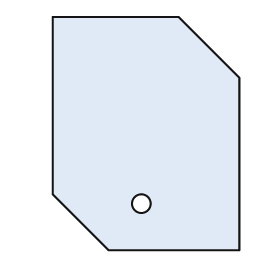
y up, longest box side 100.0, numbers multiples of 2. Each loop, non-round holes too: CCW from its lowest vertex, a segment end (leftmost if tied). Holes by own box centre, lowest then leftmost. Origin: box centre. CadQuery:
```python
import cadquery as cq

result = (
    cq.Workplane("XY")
    .moveTo(-16.0, -50.0)
    .lineTo(40.0, -50.0)
    .lineTo(40.0, 24.0)
    .lineTo(14.0, 50.0)
    .lineTo(-40.0, 50.0)
    .lineTo(-40.0, -26.0)
    .close()
    .moveTo(-2.0, -30.0)
    .circle(4.0)
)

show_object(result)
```